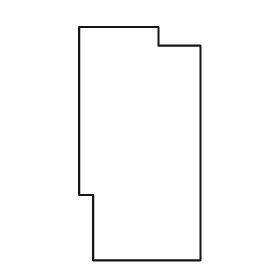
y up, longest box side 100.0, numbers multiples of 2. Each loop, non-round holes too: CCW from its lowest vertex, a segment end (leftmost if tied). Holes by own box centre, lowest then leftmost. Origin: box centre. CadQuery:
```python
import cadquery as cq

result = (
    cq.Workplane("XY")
    .moveTo(-20.0, -50.0)
    .lineTo(26.0, -50.0)
    .lineTo(26.0, 42.0)
    .lineTo(8.0, 42.0)
    .lineTo(8.0, 50.0)
    .lineTo(-26.0, 50.0)
    .lineTo(-26.0, -22.0)
    .lineTo(-20.0, -22.0)
    .close()
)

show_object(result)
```